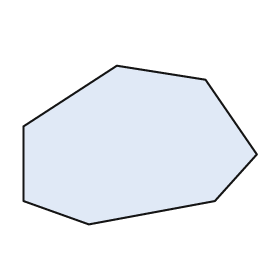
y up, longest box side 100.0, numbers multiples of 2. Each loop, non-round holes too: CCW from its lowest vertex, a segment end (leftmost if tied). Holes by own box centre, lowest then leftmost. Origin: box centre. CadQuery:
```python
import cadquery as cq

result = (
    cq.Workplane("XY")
    .moveTo(-22.0, -34.0)
    .lineTo(32.0, -24.0)
    .lineTo(50.0, -4.0)
    .lineTo(28.0, 28.0)
    .lineTo(-10.0, 34.0)
    .lineTo(-50.0, 8.0)
    .lineTo(-50.0, -24.0)
    .close()
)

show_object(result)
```